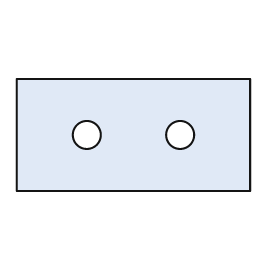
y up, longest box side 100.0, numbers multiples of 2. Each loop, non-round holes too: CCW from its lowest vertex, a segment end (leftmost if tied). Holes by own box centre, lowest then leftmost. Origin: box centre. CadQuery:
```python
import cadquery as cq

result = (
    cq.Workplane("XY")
    .moveTo(-50.0, -24.0)
    .lineTo(50.0, -24.0)
    .lineTo(50.0, 24.0)
    .lineTo(-50.0, 24.0)
    .close()
    .moveTo(-20.0, 0.0)
    .circle(6.0)
    .moveTo(20.0, 0.0)
    .circle(6.0)
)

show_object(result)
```